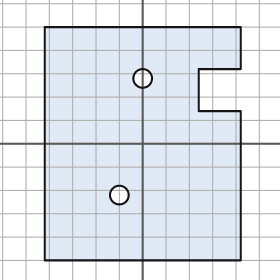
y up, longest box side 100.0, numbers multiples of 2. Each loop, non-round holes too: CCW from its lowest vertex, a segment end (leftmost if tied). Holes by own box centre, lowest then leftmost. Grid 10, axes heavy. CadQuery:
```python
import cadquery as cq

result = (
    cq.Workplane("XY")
    .moveTo(-42.0, -50.0)
    .lineTo(42.0, -50.0)
    .lineTo(42.0, 14.0)
    .lineTo(24.0, 14.0)
    .lineTo(24.0, 32.0)
    .lineTo(42.0, 32.0)
    .lineTo(42.0, 50.0)
    .lineTo(-42.0, 50.0)
    .close()
    .moveTo(-10.0, -22.0)
    .circle(4.0)
    .moveTo(0.0, 28.0)
    .circle(4.0)
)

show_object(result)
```